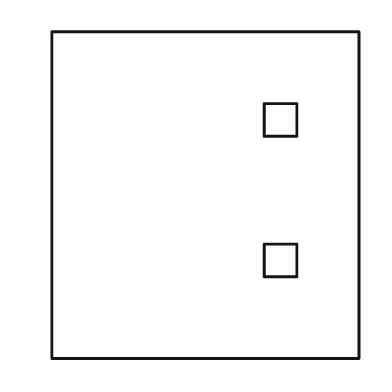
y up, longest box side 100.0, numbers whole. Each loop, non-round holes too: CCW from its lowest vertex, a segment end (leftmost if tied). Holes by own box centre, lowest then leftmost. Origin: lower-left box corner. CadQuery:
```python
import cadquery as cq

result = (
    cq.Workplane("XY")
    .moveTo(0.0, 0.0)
    .lineTo(94.0, 0.0)
    .lineTo(94.0, 100.0)
    .lineTo(0.0, 100.0)
    .close()
    .moveTo(65.0, 25.0)
    .lineTo(75.0, 25.0)
    .lineTo(75.0, 35.0)
    .lineTo(65.0, 35.0)
    .close()
    .moveTo(65.0, 68.0)
    .lineTo(75.0, 68.0)
    .lineTo(75.0, 78.0)
    .lineTo(65.0, 78.0)
    .close()
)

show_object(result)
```